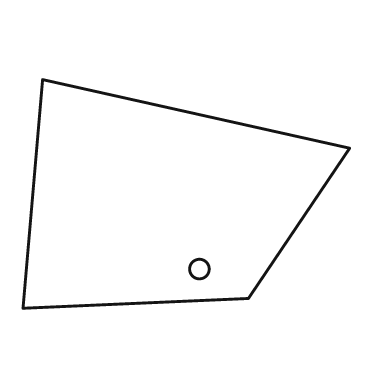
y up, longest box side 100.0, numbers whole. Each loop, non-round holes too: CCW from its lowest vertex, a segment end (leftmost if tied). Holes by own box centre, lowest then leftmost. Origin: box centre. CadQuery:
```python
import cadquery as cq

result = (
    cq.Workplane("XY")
    .moveTo(-50.0, -35.0)
    .lineTo(19.0, -32.0)
    .lineTo(50.0, 14.0)
    .lineTo(-44.0, 35.0)
    .close()
    .moveTo(4.0, -23.0)
    .circle(3.0)
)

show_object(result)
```